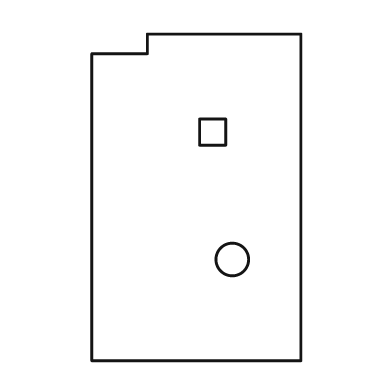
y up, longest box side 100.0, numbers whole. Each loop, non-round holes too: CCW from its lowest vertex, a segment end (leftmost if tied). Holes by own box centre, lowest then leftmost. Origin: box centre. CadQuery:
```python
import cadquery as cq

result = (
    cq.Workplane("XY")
    .moveTo(-32.0, -50.0)
    .lineTo(32.0, -50.0)
    .lineTo(32.0, 50.0)
    .lineTo(-15.0, 50.0)
    .lineTo(-15.0, 44.0)
    .lineTo(-32.0, 44.0)
    .close()
    .moveTo(11.0, -19.0)
    .circle(5.0)
    .moveTo(1.0, 16.0)
    .lineTo(9.0, 16.0)
    .lineTo(9.0, 24.0)
    .lineTo(1.0, 24.0)
    .close()
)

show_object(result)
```